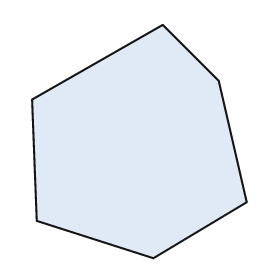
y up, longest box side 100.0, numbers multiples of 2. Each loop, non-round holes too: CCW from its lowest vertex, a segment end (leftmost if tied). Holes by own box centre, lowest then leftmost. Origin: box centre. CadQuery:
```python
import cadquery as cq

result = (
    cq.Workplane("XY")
    .moveTo(6.0, -50.0)
    .lineTo(46.0, -26.0)
    .lineTo(34.0, 26.0)
    .lineTo(10.0, 50.0)
    .lineTo(-46.0, 18.0)
    .lineTo(-44.0, -34.0)
    .close()
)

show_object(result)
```